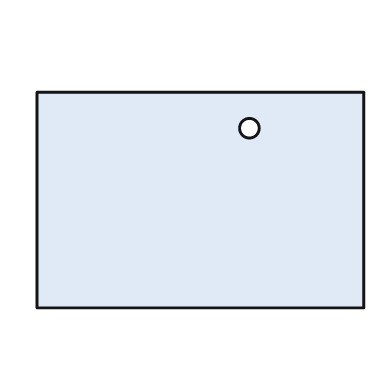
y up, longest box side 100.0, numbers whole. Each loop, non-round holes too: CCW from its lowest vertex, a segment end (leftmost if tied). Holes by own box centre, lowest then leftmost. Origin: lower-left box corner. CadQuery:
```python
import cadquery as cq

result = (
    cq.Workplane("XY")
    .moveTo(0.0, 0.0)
    .lineTo(100.0, 0.0)
    .lineTo(100.0, 66.0)
    .lineTo(0.0, 66.0)
    .close()
    .moveTo(65.0, 55.0)
    .circle(3.0)
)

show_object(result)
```